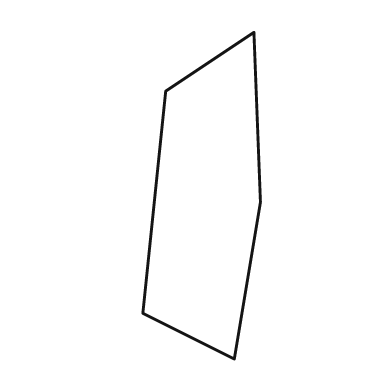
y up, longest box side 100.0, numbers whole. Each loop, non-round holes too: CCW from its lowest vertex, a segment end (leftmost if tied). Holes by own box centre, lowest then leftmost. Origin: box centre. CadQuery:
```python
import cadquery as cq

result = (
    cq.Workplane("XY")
    .moveTo(10.0, -50.0)
    .lineTo(18.0, -2.0)
    .lineTo(16.0, 50.0)
    .lineTo(-11.0, 32.0)
    .lineTo(-18.0, -36.0)
    .close()
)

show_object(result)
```